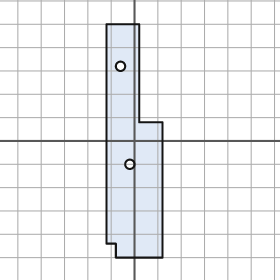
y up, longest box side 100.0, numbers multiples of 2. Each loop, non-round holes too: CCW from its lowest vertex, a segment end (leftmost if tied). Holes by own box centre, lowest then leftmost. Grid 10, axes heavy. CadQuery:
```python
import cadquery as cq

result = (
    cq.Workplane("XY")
    .moveTo(-8.0, -50.0)
    .lineTo(12.0, -50.0)
    .lineTo(12.0, 8.0)
    .lineTo(2.0, 8.0)
    .lineTo(2.0, 50.0)
    .lineTo(-12.0, 50.0)
    .lineTo(-12.0, -44.0)
    .lineTo(-8.0, -44.0)
    .close()
    .moveTo(-2.0, -10.0)
    .circle(2.0)
    .moveTo(-6.0, 32.0)
    .circle(2.0)
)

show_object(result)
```